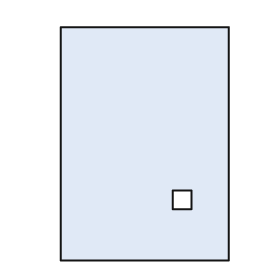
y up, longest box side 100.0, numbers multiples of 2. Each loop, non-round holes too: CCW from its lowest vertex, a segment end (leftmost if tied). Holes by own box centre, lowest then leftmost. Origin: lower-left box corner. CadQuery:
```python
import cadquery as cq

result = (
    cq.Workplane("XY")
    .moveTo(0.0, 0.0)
    .lineTo(72.0, 0.0)
    .lineTo(72.0, 100.0)
    .lineTo(0.0, 100.0)
    .close()
    .moveTo(48.0, 22.0)
    .lineTo(56.0, 22.0)
    .lineTo(56.0, 30.0)
    .lineTo(48.0, 30.0)
    .close()
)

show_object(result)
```